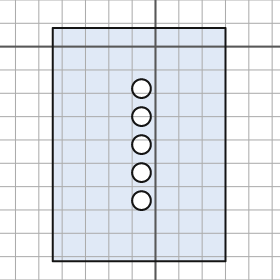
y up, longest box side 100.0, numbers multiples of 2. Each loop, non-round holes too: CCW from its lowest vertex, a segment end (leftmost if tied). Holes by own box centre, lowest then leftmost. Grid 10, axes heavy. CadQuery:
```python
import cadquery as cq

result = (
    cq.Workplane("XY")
    .moveTo(-44.0, -92.0)
    .lineTo(30.0, -92.0)
    .lineTo(30.0, 8.0)
    .lineTo(-44.0, 8.0)
    .close()
    .moveTo(-6.0, -66.0)
    .circle(4.0)
    .moveTo(-6.0, -54.0)
    .circle(4.0)
    .moveTo(-6.0, -42.0)
    .circle(4.0)
    .moveTo(-6.0, -30.0)
    .circle(4.0)
    .moveTo(-6.0, -18.0)
    .circle(4.0)
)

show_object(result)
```